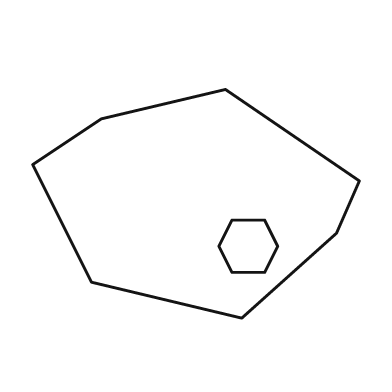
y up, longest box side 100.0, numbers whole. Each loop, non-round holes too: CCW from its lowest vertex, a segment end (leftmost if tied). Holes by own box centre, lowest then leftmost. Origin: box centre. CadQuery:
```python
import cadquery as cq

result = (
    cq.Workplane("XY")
    .moveTo(14.0, -35.0)
    .lineTo(43.0, -9.0)
    .lineTo(50.0, 7.0)
    .lineTo(9.0, 35.0)
    .lineTo(-29.0, 26.0)
    .lineTo(-50.0, 12.0)
    .lineTo(-32.0, -24.0)
    .close()
    .moveTo(11.0, -21.0)
    .lineTo(21.0, -21.0)
    .lineTo(25.0, -13.0)
    .lineTo(21.0, -5.0)
    .lineTo(11.0, -5.0)
    .lineTo(7.0, -13.0)
    .close()
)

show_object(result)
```